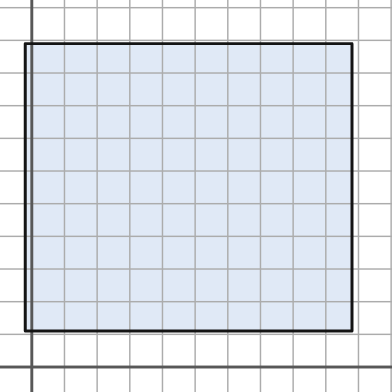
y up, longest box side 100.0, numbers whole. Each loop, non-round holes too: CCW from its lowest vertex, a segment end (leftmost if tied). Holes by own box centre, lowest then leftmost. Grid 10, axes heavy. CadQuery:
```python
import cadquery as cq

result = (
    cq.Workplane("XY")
    .moveTo(-2.0, 11.0)
    .lineTo(98.0, 11.0)
    .lineTo(98.0, 99.0)
    .lineTo(-2.0, 99.0)
    .close()
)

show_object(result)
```